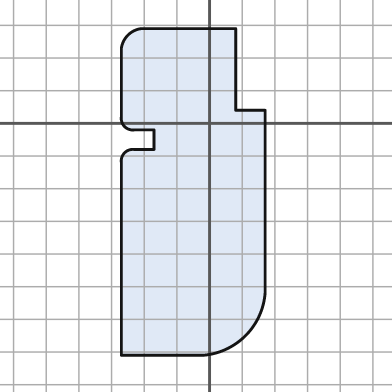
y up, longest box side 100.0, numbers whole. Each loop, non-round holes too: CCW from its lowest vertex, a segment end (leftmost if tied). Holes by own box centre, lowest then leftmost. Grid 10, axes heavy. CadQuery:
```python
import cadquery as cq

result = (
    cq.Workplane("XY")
    .moveTo(-27.0, -71.0)
    .lineTo(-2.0, -71.0)
    .threePointArc((11.0, -65.0), (17.0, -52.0))
    .lineTo(17.0, 4.0)
    .lineTo(8.0, 4.0)
    .lineTo(8.0, 29.0)
    .lineTo(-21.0, 29.0)
    .threePointArc((-25.0, 27.0), (-27.0, 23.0))
    .lineTo(-27.0, 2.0)
    .threePointArc((-26.0, -1.0), (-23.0, -2.0))
    .lineTo(-17.0, -2.0)
    .lineTo(-17.0, -8.0)
    .lineTo(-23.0, -8.0)
    .threePointArc((-26.0, -9.0), (-27.0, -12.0))
    .close()
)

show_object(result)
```